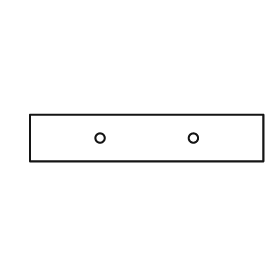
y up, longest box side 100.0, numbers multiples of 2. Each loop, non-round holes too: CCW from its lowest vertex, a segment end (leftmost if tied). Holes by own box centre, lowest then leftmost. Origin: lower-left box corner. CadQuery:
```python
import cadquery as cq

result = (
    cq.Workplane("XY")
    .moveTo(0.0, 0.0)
    .lineTo(100.0, 0.0)
    .lineTo(100.0, 20.0)
    .lineTo(0.0, 20.0)
    .close()
    .moveTo(30.0, 10.0)
    .circle(2.0)
    .moveTo(70.0, 10.0)
    .circle(2.0)
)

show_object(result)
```